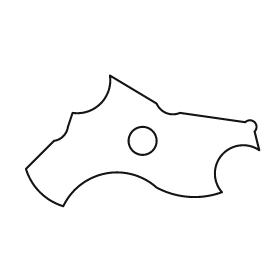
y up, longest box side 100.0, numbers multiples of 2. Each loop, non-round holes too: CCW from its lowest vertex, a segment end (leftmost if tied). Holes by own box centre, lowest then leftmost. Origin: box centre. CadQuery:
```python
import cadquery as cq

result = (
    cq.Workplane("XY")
    .moveTo(-34.0, -28.0)
    .threePointArc((-16.0, -14.0), (6.0, -20.0))
    .threePointArc((20.0, -24.0), (34.0, -22.0))
    .threePointArc((34.0, -6.0), (50.0, -4.0))
    .lineTo(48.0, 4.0)
    .threePointArc((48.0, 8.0), (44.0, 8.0))
    .lineTo(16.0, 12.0)
    .threePointArc((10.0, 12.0), (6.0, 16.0))
    .lineTo(-14.0, 28.0)
    .threePointArc((-18.0, 16.0), (-30.0, 12.0))
    .lineTo(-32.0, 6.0)
    .threePointArc((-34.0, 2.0), (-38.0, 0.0))
    .lineTo(-50.0, -12.0)
    .threePointArc((-44.0, -22.0), (-34.0, -28.0))
    .close()
    .moveTo(0.0, 0.0)
    .circle(6.0)
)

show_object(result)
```